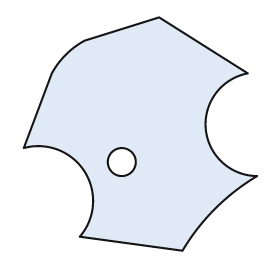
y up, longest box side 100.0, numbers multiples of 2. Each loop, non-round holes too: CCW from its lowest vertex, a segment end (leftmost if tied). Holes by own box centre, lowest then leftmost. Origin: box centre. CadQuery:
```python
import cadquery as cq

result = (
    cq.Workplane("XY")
    .moveTo(18.0, -50.0)
    .threePointArc((32.0, -32.0), (50.0, -18.0))
    .threePointArc((28.0, 2.0), (46.0, 26.0))
    .lineTo(8.0, 50.0)
    .lineTo(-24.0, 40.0)
    .threePointArc((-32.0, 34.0), (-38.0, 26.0))
    .lineTo(-50.0, -6.0)
    .threePointArc((-24.0, -16.0), (-26.0, -44.0))
    .close()
    .moveTo(-8.0, -12.0)
    .circle(6.0)
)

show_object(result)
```